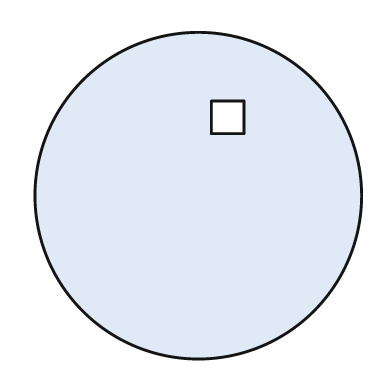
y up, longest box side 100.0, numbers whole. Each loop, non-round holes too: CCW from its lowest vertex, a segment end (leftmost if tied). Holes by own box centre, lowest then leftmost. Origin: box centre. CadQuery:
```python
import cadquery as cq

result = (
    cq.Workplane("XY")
    .moveTo(0.0, 0.0)
    .circle(50.0)
    .moveTo(4.0, 19.0)
    .lineTo(14.0, 19.0)
    .lineTo(14.0, 29.0)
    .lineTo(4.0, 29.0)
    .close()
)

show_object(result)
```